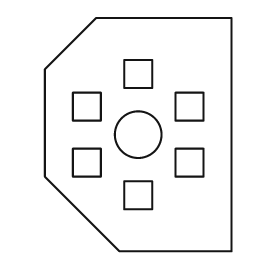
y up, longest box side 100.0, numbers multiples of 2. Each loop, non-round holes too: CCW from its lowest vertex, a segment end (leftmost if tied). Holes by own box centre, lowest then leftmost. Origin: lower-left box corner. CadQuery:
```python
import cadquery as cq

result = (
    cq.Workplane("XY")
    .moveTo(32.0, 0.0)
    .lineTo(80.0, 0.0)
    .lineTo(80.0, 100.0)
    .lineTo(22.0, 100.0)
    .lineTo(0.0, 78.0)
    .lineTo(0.0, 32.0)
    .close()
    .moveTo(34.0, 18.0)
    .lineTo(46.0, 18.0)
    .lineTo(46.0, 30.0)
    .lineTo(34.0, 30.0)
    .close()
    .moveTo(12.0, 32.0)
    .lineTo(24.0, 32.0)
    .lineTo(24.0, 44.0)
    .lineTo(12.0, 44.0)
    .close()
    .moveTo(56.0, 32.0)
    .lineTo(68.0, 32.0)
    .lineTo(68.0, 44.0)
    .lineTo(56.0, 44.0)
    .close()
    .moveTo(40.0, 50.0)
    .circle(10.0)
    .moveTo(12.0, 56.0)
    .lineTo(24.0, 56.0)
    .lineTo(24.0, 68.0)
    .lineTo(12.0, 68.0)
    .close()
    .moveTo(56.0, 56.0)
    .lineTo(68.0, 56.0)
    .lineTo(68.0, 68.0)
    .lineTo(56.0, 68.0)
    .close()
    .moveTo(34.0, 70.0)
    .lineTo(46.0, 70.0)
    .lineTo(46.0, 82.0)
    .lineTo(34.0, 82.0)
    .close()
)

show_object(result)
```